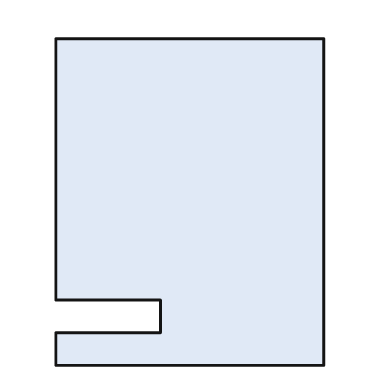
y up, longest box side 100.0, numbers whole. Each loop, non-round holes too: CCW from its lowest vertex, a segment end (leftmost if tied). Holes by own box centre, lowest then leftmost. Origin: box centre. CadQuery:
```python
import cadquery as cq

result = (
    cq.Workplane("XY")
    .moveTo(-41.0, -50.0)
    .lineTo(41.0, -50.0)
    .lineTo(41.0, 50.0)
    .lineTo(-41.0, 50.0)
    .lineTo(-41.0, -30.0)
    .lineTo(-9.0, -30.0)
    .lineTo(-9.0, -40.0)
    .lineTo(-41.0, -40.0)
    .close()
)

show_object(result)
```